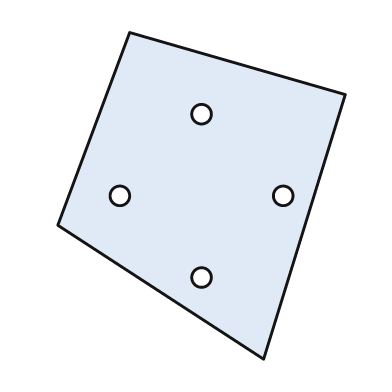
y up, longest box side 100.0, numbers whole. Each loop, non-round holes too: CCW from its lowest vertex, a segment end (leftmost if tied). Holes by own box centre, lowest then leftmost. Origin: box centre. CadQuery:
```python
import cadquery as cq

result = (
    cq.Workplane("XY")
    .moveTo(19.0, -50.0)
    .lineTo(44.0, 31.0)
    .lineTo(-22.0, 50.0)
    .lineTo(-44.0, -9.0)
    .close()
    .moveTo(0.0, -25.0)
    .circle(3.0)
    .moveTo(-25.0, 0.0)
    .circle(3.0)
    .moveTo(25.0, 0.0)
    .circle(3.0)
    .moveTo(0.0, 25.0)
    .circle(3.0)
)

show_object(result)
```